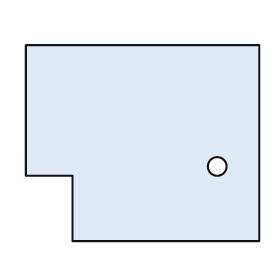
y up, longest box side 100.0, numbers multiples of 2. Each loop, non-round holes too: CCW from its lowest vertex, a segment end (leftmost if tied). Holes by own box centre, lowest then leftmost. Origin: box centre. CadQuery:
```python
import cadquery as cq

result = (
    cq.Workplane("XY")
    .moveTo(-30.0, -42.0)
    .lineTo(50.0, -42.0)
    .lineTo(50.0, 42.0)
    .lineTo(-50.0, 42.0)
    .lineTo(-50.0, -14.0)
    .lineTo(-30.0, -14.0)
    .close()
    .moveTo(32.0, -10.0)
    .circle(4.0)
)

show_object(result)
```